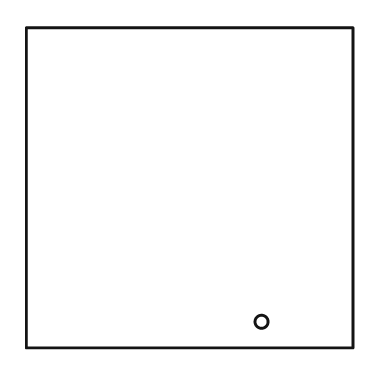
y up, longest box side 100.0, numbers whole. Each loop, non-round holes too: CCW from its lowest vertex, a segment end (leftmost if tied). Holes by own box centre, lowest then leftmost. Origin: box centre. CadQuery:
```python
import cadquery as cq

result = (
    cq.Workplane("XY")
    .moveTo(-50.0, -49.0)
    .lineTo(50.0, -49.0)
    .lineTo(50.0, 49.0)
    .lineTo(-50.0, 49.0)
    .close()
    .moveTo(22.0, -41.0)
    .circle(2.0)
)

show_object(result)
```